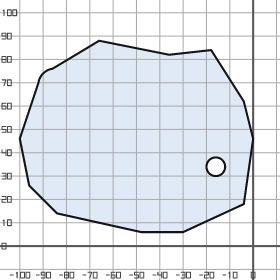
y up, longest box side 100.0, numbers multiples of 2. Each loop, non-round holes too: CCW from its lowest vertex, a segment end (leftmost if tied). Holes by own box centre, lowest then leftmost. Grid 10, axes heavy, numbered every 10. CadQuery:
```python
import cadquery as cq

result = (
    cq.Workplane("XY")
    .moveTo(-48.0, 6.0)
    .lineTo(-30.0, 6.0)
    .lineTo(-4.0, 18.0)
    .lineTo(0.0, 46.0)
    .lineTo(-4.0, 62.0)
    .lineTo(-18.0, 84.0)
    .lineTo(-36.0, 82.0)
    .lineTo(-66.0, 88.0)
    .lineTo(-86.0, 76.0)
    .threePointArc((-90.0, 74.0), (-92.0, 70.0))
    .lineTo(-100.0, 46.0)
    .lineTo(-96.0, 26.0)
    .lineTo(-84.0, 14.0)
    .close()
    .moveTo(-16.0, 34.0)
    .circle(4.0)
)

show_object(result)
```